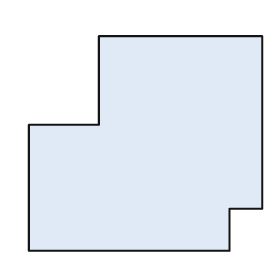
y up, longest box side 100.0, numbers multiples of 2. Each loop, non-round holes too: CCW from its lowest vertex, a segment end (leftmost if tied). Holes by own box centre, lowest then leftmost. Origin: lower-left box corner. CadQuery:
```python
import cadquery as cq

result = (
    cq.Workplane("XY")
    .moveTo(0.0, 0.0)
    .lineTo(86.0, 0.0)
    .lineTo(86.0, 18.0)
    .lineTo(100.0, 18.0)
    .lineTo(100.0, 92.0)
    .lineTo(30.0, 92.0)
    .lineTo(30.0, 54.0)
    .lineTo(0.0, 54.0)
    .close()
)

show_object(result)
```